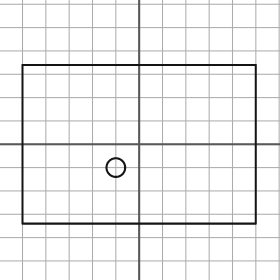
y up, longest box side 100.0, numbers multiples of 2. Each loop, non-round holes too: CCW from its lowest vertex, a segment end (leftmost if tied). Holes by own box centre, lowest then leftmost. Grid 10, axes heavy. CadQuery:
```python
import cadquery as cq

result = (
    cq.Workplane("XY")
    .moveTo(-50.0, -34.0)
    .lineTo(50.0, -34.0)
    .lineTo(50.0, 34.0)
    .lineTo(-50.0, 34.0)
    .close()
    .moveTo(-10.0, -10.0)
    .circle(4.0)
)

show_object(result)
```